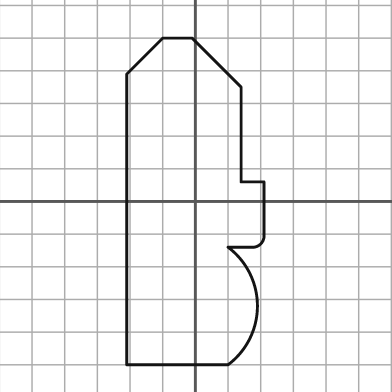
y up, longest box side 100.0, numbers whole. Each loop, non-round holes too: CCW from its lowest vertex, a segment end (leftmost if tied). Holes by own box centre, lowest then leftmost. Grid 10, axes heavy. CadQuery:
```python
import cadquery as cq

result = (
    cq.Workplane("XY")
    .moveTo(-21.0, -50.0)
    .lineTo(10.0, -50.0)
    .threePointArc((19.0, -32.0), (10.0, -14.0))
    .lineTo(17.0, -14.0)
    .threePointArc((20.0, -13.0), (21.0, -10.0))
    .lineTo(21.0, 6.0)
    .lineTo(14.0, 6.0)
    .lineTo(14.0, 35.0)
    .lineTo(-1.0, 50.0)
    .lineTo(-10.0, 50.0)
    .lineTo(-21.0, 39.0)
    .close()
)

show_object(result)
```